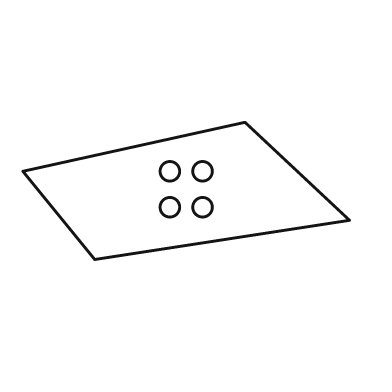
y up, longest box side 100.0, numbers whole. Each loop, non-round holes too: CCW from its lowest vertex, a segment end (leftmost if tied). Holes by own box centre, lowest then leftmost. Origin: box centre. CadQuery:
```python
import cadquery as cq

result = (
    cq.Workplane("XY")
    .moveTo(-28.0, -21.0)
    .lineTo(50.0, -9.0)
    .lineTo(18.0, 21.0)
    .lineTo(-50.0, 6.0)
    .close()
    .moveTo(-5.0, -5.0)
    .circle(3.0)
    .moveTo(5.0, -5.0)
    .circle(3.0)
    .moveTo(-5.0, 6.0)
    .circle(3.0)
    .moveTo(5.0, 6.0)
    .circle(3.0)
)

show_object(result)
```